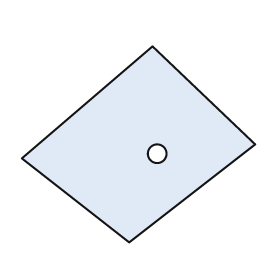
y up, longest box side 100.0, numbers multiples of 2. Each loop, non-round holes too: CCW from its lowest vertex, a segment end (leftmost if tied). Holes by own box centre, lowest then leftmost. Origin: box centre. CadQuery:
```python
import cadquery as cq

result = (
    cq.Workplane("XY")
    .moveTo(-4.0, -42.0)
    .lineTo(50.0, 0.0)
    .lineTo(6.0, 42.0)
    .lineTo(-50.0, -6.0)
    .close()
    .moveTo(8.0, -4.0)
    .circle(4.0)
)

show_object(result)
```